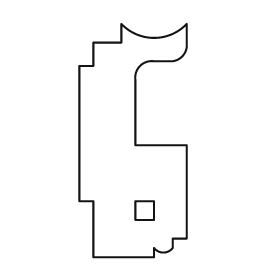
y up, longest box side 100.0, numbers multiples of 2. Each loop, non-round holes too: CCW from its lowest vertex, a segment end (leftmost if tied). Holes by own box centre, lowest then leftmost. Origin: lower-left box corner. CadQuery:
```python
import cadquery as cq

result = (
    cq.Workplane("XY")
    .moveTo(6.0, 0.0)
    .lineTo(32.0, 0.0)
    .lineTo(32.0, 4.0)
    .threePointArc((36.0, 2.0), (40.0, 4.0))
    .lineTo(40.0, 8.0)
    .lineTo(46.0, 8.0)
    .lineTo(46.0, 48.0)
    .lineTo(24.0, 48.0)
    .lineTo(24.0, 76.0)
    .threePointArc((26.0, 82.0), (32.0, 84.0))
    .lineTo(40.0, 84.0)
    .threePointArc((44.0, 86.0), (46.0, 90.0))
    .lineTo(46.0, 100.0)
    .threePointArc((32.0, 94.0), (18.0, 100.0))
    .lineTo(18.0, 92.0)
    .lineTo(6.0, 92.0)
    .lineTo(6.0, 82.0)
    .lineTo(0.0, 82.0)
    .lineTo(0.0, 24.0)
    .lineTo(6.0, 24.0)
    .close()
    .moveTo(24.0, 16.0)
    .lineTo(32.0, 16.0)
    .lineTo(32.0, 24.0)
    .lineTo(24.0, 24.0)
    .close()
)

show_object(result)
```